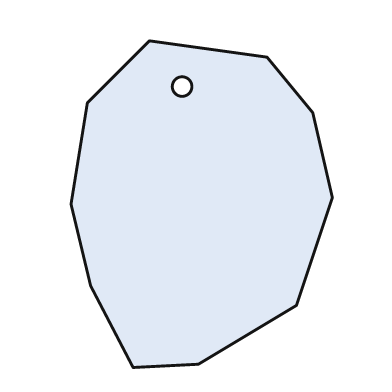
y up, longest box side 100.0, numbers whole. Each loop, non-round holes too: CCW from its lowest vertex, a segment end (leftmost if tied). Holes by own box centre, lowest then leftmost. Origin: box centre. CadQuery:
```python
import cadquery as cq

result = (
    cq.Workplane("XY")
    .moveTo(-21.0, -50.0)
    .lineTo(-1.0, -49.0)
    .lineTo(29.0, -31.0)
    .lineTo(40.0, 2.0)
    .lineTo(34.0, 28.0)
    .lineTo(20.0, 45.0)
    .lineTo(-16.0, 50.0)
    .lineTo(-35.0, 31.0)
    .lineTo(-40.0, 0.0)
    .lineTo(-34.0, -25.0)
    .close()
    .moveTo(-6.0, 36.0)
    .circle(3.0)
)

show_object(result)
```